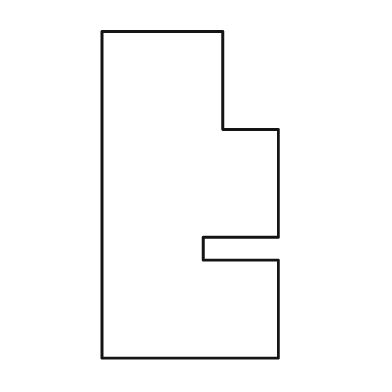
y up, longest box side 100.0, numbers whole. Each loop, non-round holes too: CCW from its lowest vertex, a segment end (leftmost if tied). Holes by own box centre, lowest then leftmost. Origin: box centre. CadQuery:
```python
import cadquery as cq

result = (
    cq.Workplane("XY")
    .moveTo(-27.0, -50.0)
    .lineTo(27.0, -50.0)
    .lineTo(27.0, -20.0)
    .lineTo(4.0, -20.0)
    .lineTo(4.0, -13.0)
    .lineTo(27.0, -13.0)
    .lineTo(27.0, 20.0)
    .lineTo(10.0, 20.0)
    .lineTo(10.0, 50.0)
    .lineTo(-27.0, 50.0)
    .close()
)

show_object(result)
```